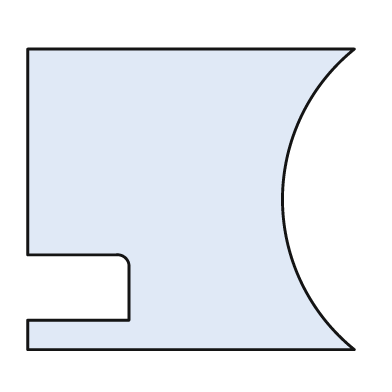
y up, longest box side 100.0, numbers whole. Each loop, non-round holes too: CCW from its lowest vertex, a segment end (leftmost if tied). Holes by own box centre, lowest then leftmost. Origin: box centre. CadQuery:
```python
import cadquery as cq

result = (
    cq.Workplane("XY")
    .moveTo(-50.0, -46.0)
    .lineTo(50.0, -46.0)
    .threePointArc((28.0, 0.0), (50.0, 46.0))
    .lineTo(-50.0, 46.0)
    .lineTo(-50.0, -17.0)
    .lineTo(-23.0, -17.0)
    .threePointArc((-20.0, -18.0), (-19.0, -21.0))
    .lineTo(-19.0, -37.0)
    .lineTo(-50.0, -37.0)
    .close()
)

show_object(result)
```